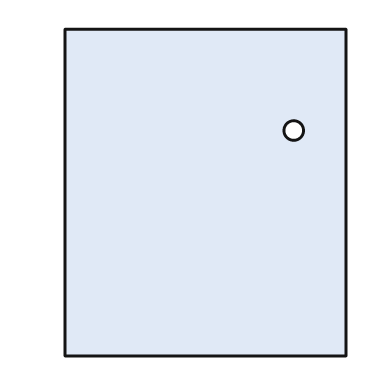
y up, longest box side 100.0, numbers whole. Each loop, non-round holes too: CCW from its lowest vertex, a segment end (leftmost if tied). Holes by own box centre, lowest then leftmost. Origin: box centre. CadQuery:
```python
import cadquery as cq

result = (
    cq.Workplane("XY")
    .moveTo(-43.0, -50.0)
    .lineTo(43.0, -50.0)
    .lineTo(43.0, 50.0)
    .lineTo(-43.0, 50.0)
    .close()
    .moveTo(27.0, 19.0)
    .circle(3.0)
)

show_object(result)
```